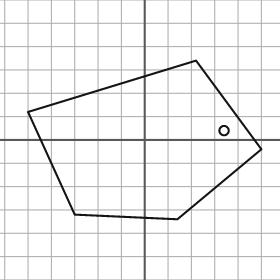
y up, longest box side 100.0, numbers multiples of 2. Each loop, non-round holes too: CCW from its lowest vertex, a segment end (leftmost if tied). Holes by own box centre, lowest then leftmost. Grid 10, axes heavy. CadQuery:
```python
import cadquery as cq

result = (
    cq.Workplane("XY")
    .moveTo(14.0, -34.0)
    .lineTo(50.0, -4.0)
    .lineTo(22.0, 34.0)
    .lineTo(-50.0, 12.0)
    .lineTo(-30.0, -32.0)
    .close()
    .moveTo(34.0, 4.0)
    .circle(2.0)
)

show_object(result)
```